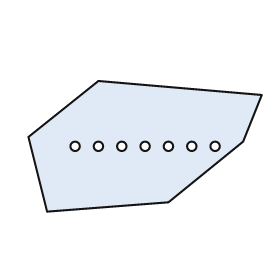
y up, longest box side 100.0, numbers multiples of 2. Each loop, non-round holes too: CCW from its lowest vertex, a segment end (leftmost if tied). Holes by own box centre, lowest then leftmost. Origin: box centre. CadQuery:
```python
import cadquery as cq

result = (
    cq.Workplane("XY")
    .moveTo(-42.0, -28.0)
    .lineTo(10.0, -24.0)
    .lineTo(42.0, 2.0)
    .lineTo(50.0, 22.0)
    .lineTo(-20.0, 28.0)
    .lineTo(-50.0, 4.0)
    .close()
    .moveTo(-30.0, 0.0)
    .circle(2.0)
    .moveTo(-20.0, 0.0)
    .circle(2.0)
    .moveTo(-10.0, 0.0)
    .circle(2.0)
    .moveTo(0.0, 0.0)
    .circle(2.0)
    .moveTo(10.0, 0.0)
    .circle(2.0)
    .moveTo(20.0, 0.0)
    .circle(2.0)
    .moveTo(30.0, 0.0)
    .circle(2.0)
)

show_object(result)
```